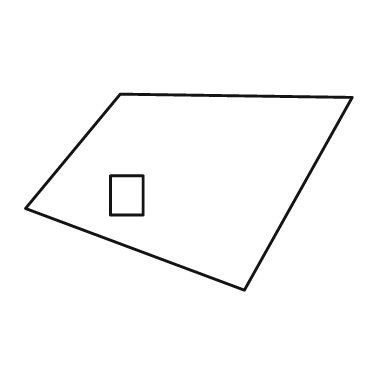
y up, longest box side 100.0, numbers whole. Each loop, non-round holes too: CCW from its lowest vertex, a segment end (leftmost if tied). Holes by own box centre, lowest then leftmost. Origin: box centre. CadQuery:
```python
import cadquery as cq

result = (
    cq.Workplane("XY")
    .moveTo(17.0, -30.0)
    .lineTo(50.0, 29.0)
    .lineTo(-21.0, 30.0)
    .lineTo(-50.0, -5.0)
    .close()
    .moveTo(-24.0, -7.0)
    .lineTo(-14.0, -7.0)
    .lineTo(-14.0, 5.0)
    .lineTo(-24.0, 5.0)
    .close()
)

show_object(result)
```